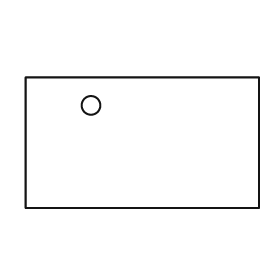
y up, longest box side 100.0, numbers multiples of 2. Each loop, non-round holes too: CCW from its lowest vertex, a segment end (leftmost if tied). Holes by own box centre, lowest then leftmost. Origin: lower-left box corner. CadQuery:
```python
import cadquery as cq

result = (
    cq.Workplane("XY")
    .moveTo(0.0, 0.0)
    .lineTo(100.0, 0.0)
    .lineTo(100.0, 56.0)
    .lineTo(0.0, 56.0)
    .close()
    .moveTo(28.0, 44.0)
    .circle(4.0)
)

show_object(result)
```